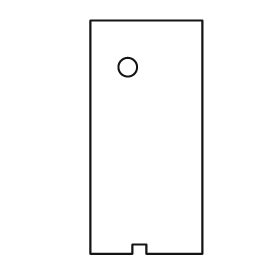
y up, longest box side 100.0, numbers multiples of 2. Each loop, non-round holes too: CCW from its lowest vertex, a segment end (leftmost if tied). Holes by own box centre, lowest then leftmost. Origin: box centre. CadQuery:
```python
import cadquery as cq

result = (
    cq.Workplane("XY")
    .moveTo(-24.0, -50.0)
    .lineTo(-6.0, -50.0)
    .lineTo(-6.0, -46.0)
    .lineTo(0.0, -46.0)
    .lineTo(0.0, -50.0)
    .lineTo(24.0, -50.0)
    .lineTo(24.0, 50.0)
    .lineTo(-24.0, 50.0)
    .close()
    .moveTo(-8.0, 30.0)
    .circle(4.0)
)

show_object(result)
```